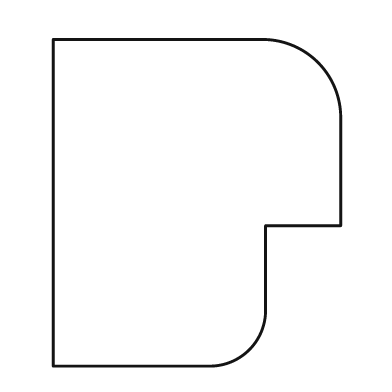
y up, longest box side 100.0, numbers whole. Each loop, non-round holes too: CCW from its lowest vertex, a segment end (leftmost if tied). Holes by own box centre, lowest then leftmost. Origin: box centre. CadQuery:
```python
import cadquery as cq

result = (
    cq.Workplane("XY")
    .moveTo(-44.0, -50.0)
    .lineTo(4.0, -50.0)
    .threePointArc((16.0, -45.0), (21.0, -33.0))
    .lineTo(21.0, -7.0)
    .lineTo(44.0, -7.0)
    .lineTo(44.0, 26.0)
    .threePointArc((37.0, 43.0), (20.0, 50.0))
    .lineTo(-44.0, 50.0)
    .close()
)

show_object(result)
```